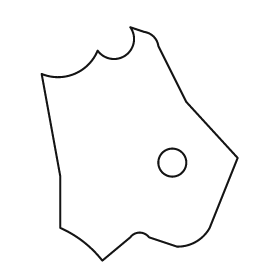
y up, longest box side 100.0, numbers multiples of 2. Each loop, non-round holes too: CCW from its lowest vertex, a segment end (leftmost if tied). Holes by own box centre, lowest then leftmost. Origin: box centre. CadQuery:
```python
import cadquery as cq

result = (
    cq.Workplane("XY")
    .moveTo(-16.0, -50.0)
    .lineTo(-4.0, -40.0)
    .threePointArc((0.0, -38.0), (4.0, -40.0))
    .lineTo(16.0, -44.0)
    .threePointArc((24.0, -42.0), (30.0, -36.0))
    .lineTo(42.0, -6.0)
    .lineTo(20.0, 18.0)
    .lineTo(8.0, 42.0)
    .threePointArc((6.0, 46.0), (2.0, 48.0))
    .lineTo(-4.0, 50.0)
    .threePointArc((-6.0, 38.0), (-18.0, 40.0))
    .threePointArc((-28.0, 30.0), (-42.0, 30.0))
    .lineTo(-34.0, -14.0)
    .lineTo(-34.0, -36.0)
    .threePointArc((-24.0, -42.0), (-16.0, -50.0))
    .close()
    .moveTo(14.0, -8.0)
    .circle(6.0)
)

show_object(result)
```